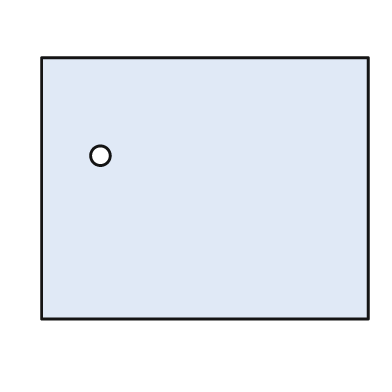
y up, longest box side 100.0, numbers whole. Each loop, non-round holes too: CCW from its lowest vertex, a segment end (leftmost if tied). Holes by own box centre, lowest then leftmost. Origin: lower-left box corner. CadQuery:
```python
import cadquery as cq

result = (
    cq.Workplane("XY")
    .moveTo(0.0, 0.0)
    .lineTo(100.0, 0.0)
    .lineTo(100.0, 80.0)
    .lineTo(0.0, 80.0)
    .close()
    .moveTo(18.0, 50.0)
    .circle(3.0)
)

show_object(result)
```